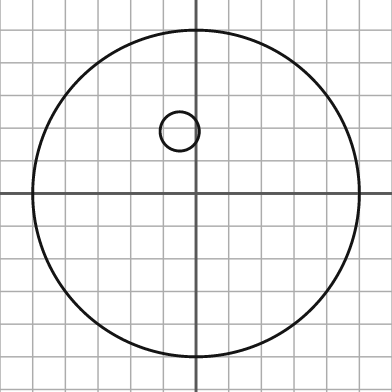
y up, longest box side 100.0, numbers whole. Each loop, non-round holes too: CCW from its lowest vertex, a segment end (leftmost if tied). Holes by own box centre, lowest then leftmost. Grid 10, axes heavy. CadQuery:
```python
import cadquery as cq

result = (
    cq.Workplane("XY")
    .moveTo(0.0, 0.0)
    .circle(50.0)
    .moveTo(-5.0, 19.0)
    .circle(6.0)
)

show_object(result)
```